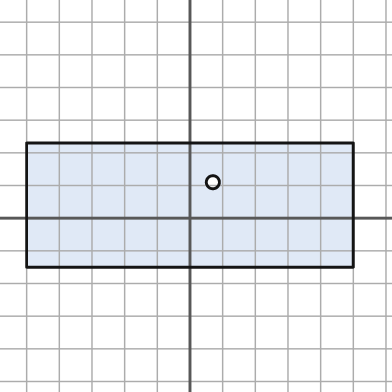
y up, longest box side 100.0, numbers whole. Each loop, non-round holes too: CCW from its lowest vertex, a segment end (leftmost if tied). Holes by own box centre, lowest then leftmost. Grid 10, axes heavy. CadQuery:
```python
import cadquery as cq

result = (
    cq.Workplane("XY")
    .moveTo(-50.0, -15.0)
    .lineTo(50.0, -15.0)
    .lineTo(50.0, 23.0)
    .lineTo(-50.0, 23.0)
    .close()
    .moveTo(7.0, 11.0)
    .circle(2.0)
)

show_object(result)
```